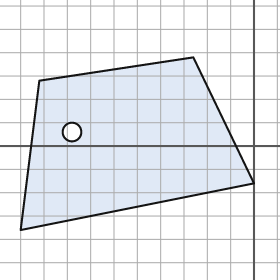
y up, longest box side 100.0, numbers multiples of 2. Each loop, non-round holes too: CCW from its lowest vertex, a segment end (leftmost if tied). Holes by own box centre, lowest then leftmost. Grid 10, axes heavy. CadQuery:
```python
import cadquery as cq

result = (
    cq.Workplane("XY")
    .moveTo(-100.0, -36.0)
    .lineTo(0.0, -16.0)
    .lineTo(-26.0, 38.0)
    .lineTo(-92.0, 28.0)
    .close()
    .moveTo(-78.0, 6.0)
    .circle(4.0)
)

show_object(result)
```